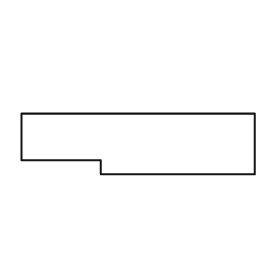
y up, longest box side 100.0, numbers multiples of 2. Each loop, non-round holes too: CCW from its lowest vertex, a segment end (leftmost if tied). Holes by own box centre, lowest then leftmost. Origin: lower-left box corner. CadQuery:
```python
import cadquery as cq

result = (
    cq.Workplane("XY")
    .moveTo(34.0, 0.0)
    .lineTo(100.0, 0.0)
    .lineTo(100.0, 26.0)
    .lineTo(0.0, 26.0)
    .lineTo(0.0, 6.0)
    .lineTo(34.0, 6.0)
    .close()
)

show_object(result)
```